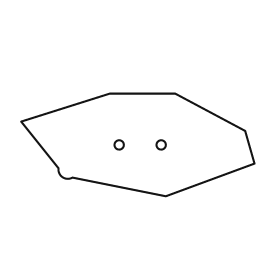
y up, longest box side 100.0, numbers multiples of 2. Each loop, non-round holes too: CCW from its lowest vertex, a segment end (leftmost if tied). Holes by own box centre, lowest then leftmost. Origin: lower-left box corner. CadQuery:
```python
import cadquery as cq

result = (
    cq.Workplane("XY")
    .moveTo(62.0, 0.0)
    .lineTo(100.0, 14.0)
    .lineTo(96.0, 28.0)
    .lineTo(66.0, 44.0)
    .lineTo(38.0, 44.0)
    .lineTo(0.0, 32.0)
    .lineTo(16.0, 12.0)
    .threePointArc((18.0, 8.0), (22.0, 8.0))
    .close()
    .moveTo(42.0, 22.0)
    .circle(2.0)
    .moveTo(60.0, 22.0)
    .circle(2.0)
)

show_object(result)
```